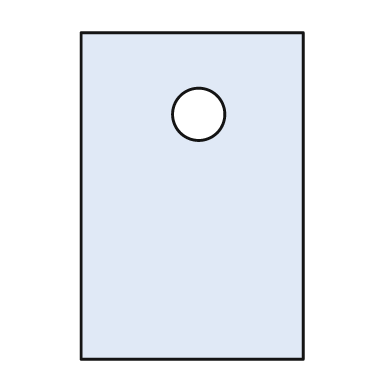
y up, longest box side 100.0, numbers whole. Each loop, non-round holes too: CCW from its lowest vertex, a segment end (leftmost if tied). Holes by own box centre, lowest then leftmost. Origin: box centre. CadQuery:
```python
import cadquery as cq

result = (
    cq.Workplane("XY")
    .moveTo(-34.0, -50.0)
    .lineTo(34.0, -50.0)
    .lineTo(34.0, 50.0)
    .lineTo(-34.0, 50.0)
    .close()
    .moveTo(2.0, 25.0)
    .circle(8.0)
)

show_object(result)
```